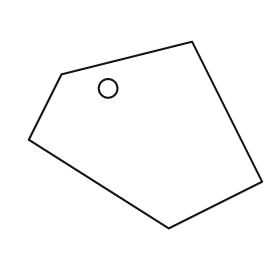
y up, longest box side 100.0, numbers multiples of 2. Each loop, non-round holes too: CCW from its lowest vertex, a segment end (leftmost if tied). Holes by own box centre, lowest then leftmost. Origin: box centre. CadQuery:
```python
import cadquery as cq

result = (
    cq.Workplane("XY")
    .moveTo(10.0, -40.0)
    .lineTo(50.0, -20.0)
    .lineTo(20.0, 40.0)
    .lineTo(-36.0, 26.0)
    .lineTo(-50.0, -2.0)
    .close()
    .moveTo(-16.0, 20.0)
    .circle(4.0)
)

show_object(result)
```